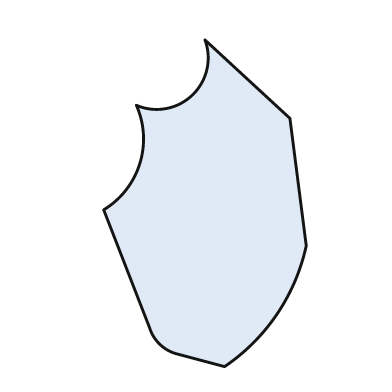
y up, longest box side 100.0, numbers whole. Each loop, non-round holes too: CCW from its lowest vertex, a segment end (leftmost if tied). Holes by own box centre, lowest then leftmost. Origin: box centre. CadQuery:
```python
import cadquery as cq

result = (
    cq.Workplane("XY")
    .moveTo(6.0, -50.0)
    .threePointArc((22.0, -34.0), (31.0, -13.0))
    .lineTo(26.0, 26.0)
    .lineTo(0.0, 50.0)
    .threePointArc((-4.0, 33.0), (-21.0, 30.0))
    .threePointArc((-20.0, 12.0), (-31.0, -2.0))
    .lineTo(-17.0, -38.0)
    .threePointArc((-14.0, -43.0), (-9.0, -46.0))
    .close()
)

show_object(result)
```